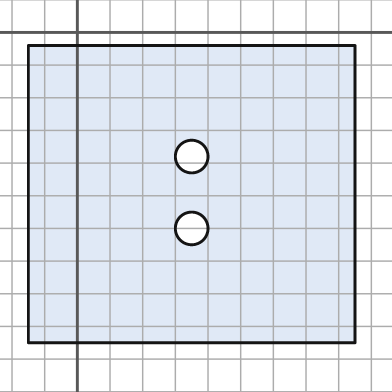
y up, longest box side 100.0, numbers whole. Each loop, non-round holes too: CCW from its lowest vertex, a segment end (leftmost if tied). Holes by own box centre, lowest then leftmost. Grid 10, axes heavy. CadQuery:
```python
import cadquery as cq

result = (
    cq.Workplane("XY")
    .moveTo(-15.0, -95.0)
    .lineTo(85.0, -95.0)
    .lineTo(85.0, -4.0)
    .lineTo(-15.0, -4.0)
    .close()
    .moveTo(35.0, -60.0)
    .circle(5.0)
    .moveTo(35.0, -38.0)
    .circle(5.0)
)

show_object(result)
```